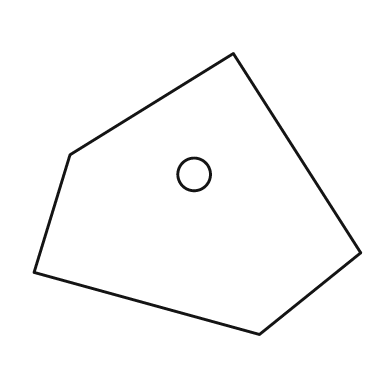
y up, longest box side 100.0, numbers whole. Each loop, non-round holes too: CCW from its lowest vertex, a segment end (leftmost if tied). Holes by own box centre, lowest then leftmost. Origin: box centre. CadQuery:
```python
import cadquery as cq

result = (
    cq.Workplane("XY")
    .moveTo(19.0, -43.0)
    .lineTo(50.0, -18.0)
    .lineTo(11.0, 43.0)
    .lineTo(-39.0, 12.0)
    .lineTo(-50.0, -24.0)
    .close()
    .moveTo(-1.0, 6.0)
    .circle(5.0)
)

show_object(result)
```